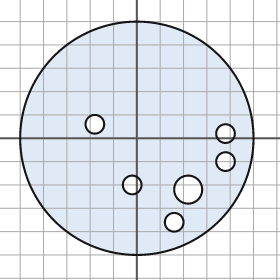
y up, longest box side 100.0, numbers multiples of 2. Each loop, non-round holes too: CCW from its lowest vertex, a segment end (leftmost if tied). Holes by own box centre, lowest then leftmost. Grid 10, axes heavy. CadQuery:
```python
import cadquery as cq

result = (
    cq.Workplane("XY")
    .moveTo(0.0, 0.0)
    .circle(50.0)
    .moveTo(16.0, -36.0)
    .circle(4.0)
    .moveTo(22.0, -22.0)
    .circle(6.0)
    .moveTo(-2.0, -20.0)
    .circle(4.0)
    .moveTo(38.0, -10.0)
    .circle(4.0)
    .moveTo(38.0, 2.0)
    .circle(4.0)
    .moveTo(-18.0, 6.0)
    .circle(4.0)
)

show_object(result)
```